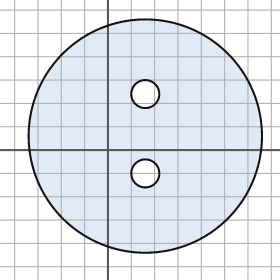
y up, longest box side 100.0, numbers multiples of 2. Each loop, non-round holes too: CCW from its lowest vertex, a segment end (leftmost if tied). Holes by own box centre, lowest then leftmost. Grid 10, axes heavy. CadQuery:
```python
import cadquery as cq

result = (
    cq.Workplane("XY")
    .moveTo(16.0, 6.0)
    .circle(50.0)
    .moveTo(16.0, -10.0)
    .circle(6.0)
    .moveTo(16.0, 24.0)
    .circle(6.0)
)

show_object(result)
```